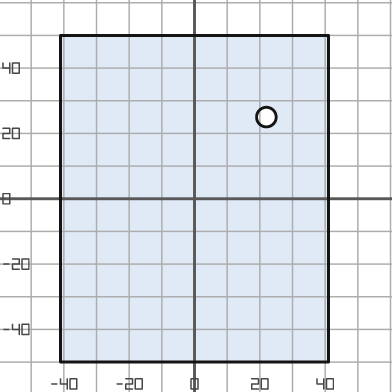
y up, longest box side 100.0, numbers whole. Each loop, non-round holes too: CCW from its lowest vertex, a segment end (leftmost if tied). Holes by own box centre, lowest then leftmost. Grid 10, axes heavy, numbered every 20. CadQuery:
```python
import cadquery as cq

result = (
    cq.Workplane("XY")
    .moveTo(-41.0, -50.0)
    .lineTo(41.0, -50.0)
    .lineTo(41.0, 50.0)
    .lineTo(-41.0, 50.0)
    .close()
    .moveTo(22.0, 25.0)
    .circle(3.0)
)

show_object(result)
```